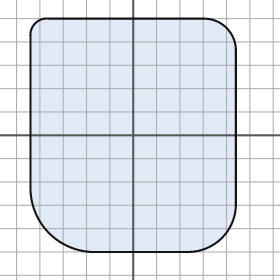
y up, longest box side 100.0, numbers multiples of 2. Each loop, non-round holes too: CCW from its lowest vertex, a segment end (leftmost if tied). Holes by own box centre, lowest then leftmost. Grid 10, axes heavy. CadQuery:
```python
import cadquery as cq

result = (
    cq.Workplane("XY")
    .moveTo(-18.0, -50.0)
    .lineTo(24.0, -50.0)
    .threePointArc((38.0, -44.0), (44.0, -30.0))
    .lineTo(44.0, 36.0)
    .threePointArc((40.0, 46.0), (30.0, 50.0))
    .lineTo(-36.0, 50.0)
    .threePointArc((-42.0, 48.0), (-44.0, 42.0))
    .lineTo(-44.0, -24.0)
    .threePointArc((-36.0, -42.0), (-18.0, -50.0))
    .close()
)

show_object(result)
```